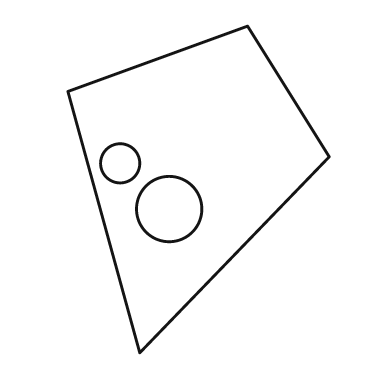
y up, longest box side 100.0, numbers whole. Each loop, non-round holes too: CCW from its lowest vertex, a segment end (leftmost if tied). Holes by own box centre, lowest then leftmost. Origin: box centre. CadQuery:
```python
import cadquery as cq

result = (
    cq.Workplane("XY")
    .moveTo(-18.0, -50.0)
    .lineTo(40.0, 10.0)
    .lineTo(15.0, 50.0)
    .lineTo(-40.0, 30.0)
    .close()
    .moveTo(-9.0, -6.0)
    .circle(10.0)
    .moveTo(-24.0, 8.0)
    .circle(6.0)
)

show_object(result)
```